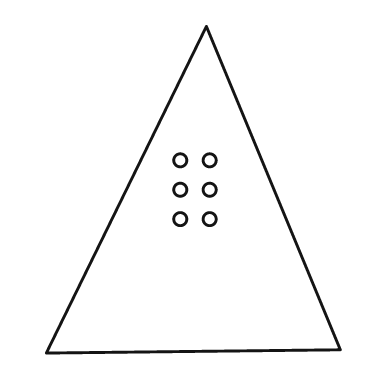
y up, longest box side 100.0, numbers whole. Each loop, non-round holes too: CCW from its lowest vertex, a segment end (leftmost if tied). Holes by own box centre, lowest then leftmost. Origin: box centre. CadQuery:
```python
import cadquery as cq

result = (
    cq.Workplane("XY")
    .moveTo(-45.0, -50.0)
    .lineTo(45.0, -49.0)
    .lineTo(4.0, 50.0)
    .close()
    .moveTo(-4.0, -9.0)
    .circle(2.0)
    .moveTo(5.0, -9.0)
    .circle(2.0)
    .moveTo(-4.0, 0.0)
    .circle(2.0)
    .moveTo(5.0, 0.0)
    .circle(2.0)
    .moveTo(-4.0, 9.0)
    .circle(2.0)
    .moveTo(5.0, 9.0)
    .circle(2.0)
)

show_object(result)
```